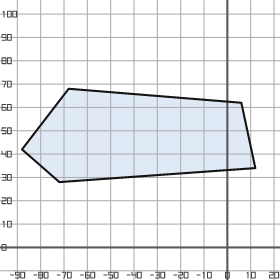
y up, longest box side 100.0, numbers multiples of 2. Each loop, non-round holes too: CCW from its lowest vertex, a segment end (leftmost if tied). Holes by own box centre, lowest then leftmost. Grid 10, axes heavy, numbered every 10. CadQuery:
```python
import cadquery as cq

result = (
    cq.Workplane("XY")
    .moveTo(-72.0, 28.0)
    .lineTo(12.0, 34.0)
    .lineTo(6.0, 62.0)
    .lineTo(-68.0, 68.0)
    .lineTo(-88.0, 42.0)
    .close()
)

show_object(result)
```